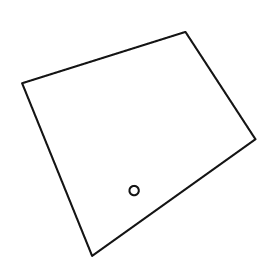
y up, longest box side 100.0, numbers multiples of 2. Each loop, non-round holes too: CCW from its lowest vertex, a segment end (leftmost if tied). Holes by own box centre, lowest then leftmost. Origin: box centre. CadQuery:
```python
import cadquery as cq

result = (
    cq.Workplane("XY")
    .moveTo(-20.0, -48.0)
    .lineTo(50.0, 2.0)
    .lineTo(20.0, 48.0)
    .lineTo(-50.0, 26.0)
    .close()
    .moveTo(-2.0, -20.0)
    .circle(2.0)
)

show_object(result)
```